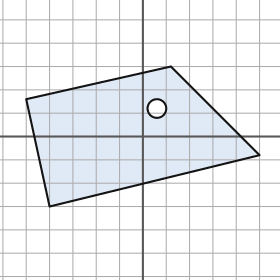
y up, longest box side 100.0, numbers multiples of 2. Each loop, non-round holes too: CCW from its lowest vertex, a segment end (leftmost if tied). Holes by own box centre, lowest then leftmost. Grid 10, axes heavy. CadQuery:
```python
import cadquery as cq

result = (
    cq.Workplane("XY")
    .moveTo(-40.0, -30.0)
    .lineTo(50.0, -8.0)
    .lineTo(12.0, 30.0)
    .lineTo(-50.0, 16.0)
    .close()
    .moveTo(6.0, 12.0)
    .circle(4.0)
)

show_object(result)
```